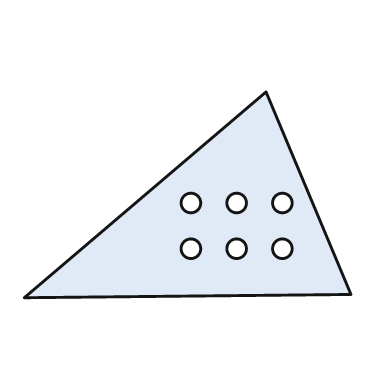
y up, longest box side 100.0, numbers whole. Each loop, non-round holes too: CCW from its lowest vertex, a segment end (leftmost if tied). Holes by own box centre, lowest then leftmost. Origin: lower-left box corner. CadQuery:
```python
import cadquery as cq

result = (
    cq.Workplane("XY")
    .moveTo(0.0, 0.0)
    .lineTo(100.0, 1.0)
    .lineTo(74.0, 63.0)
    .close()
    .moveTo(51.0, 15.0)
    .circle(3.0)
    .moveTo(65.0, 15.0)
    .circle(3.0)
    .moveTo(79.0, 15.0)
    .circle(3.0)
    .moveTo(51.0, 29.0)
    .circle(3.0)
    .moveTo(65.0, 29.0)
    .circle(3.0)
    .moveTo(79.0, 29.0)
    .circle(3.0)
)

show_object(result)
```